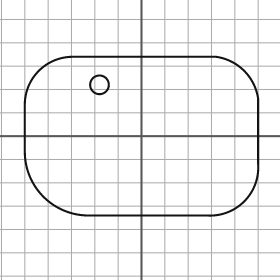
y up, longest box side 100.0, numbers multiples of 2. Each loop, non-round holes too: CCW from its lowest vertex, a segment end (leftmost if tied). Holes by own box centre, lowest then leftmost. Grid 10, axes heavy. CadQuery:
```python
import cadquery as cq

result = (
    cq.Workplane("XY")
    .moveTo(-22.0, -34.0)
    .lineTo(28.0, -34.0)
    .threePointArc((44.0, -28.0), (50.0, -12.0))
    .lineTo(50.0, 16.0)
    .threePointArc((44.0, 28.0), (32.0, 34.0))
    .lineTo(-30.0, 34.0)
    .threePointArc((-44.0, 28.0), (-50.0, 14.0))
    .lineTo(-50.0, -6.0)
    .threePointArc((-42.0, -26.0), (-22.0, -34.0))
    .close()
    .moveTo(-18.0, 22.0)
    .circle(4.0)
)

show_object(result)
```